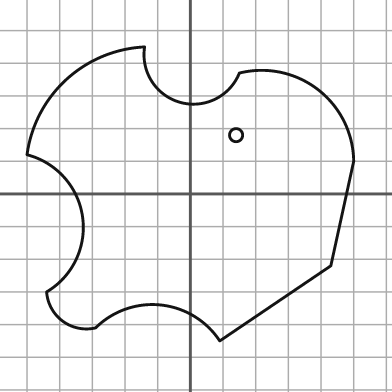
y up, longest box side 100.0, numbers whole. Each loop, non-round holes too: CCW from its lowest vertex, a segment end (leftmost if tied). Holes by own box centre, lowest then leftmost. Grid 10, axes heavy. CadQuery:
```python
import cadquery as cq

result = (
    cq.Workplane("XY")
    .moveTo(9.0, -45.0)
    .lineTo(43.0, -22.0)
    .lineTo(50.0, 10.0)
    .threePointArc((39.0, 32.0), (15.0, 37.0))
    .threePointArc((-3.0, 28.0), (-14.0, 45.0))
    .threePointArc((-38.0, 35.0), (-50.0, 12.0))
    .threePointArc((-33.0, -7.0), (-44.0, -30.0))
    .threePointArc((-39.0, -39.0), (-29.0, -41.0))
    .threePointArc((-9.0, -34.0), (9.0, -45.0))
    .close()
    .moveTo(14.0, 18.0)
    .circle(2.0)
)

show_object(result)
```